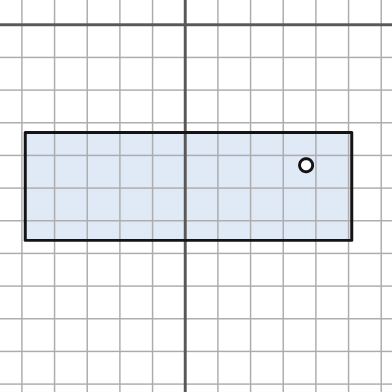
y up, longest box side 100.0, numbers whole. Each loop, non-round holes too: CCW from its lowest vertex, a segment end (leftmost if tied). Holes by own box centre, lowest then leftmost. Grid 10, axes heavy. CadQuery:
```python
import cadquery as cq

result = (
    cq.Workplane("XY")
    .moveTo(-49.0, -66.0)
    .lineTo(51.0, -66.0)
    .lineTo(51.0, -33.0)
    .lineTo(-49.0, -33.0)
    .close()
    .moveTo(37.0, -43.0)
    .circle(2.0)
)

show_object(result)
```